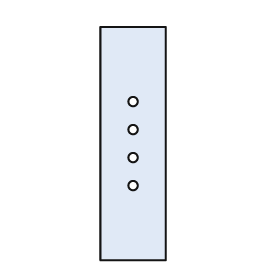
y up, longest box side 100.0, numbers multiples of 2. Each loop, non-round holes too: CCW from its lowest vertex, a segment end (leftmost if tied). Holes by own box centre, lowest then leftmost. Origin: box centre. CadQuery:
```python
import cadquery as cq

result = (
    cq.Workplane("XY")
    .moveTo(-14.0, -50.0)
    .lineTo(14.0, -50.0)
    .lineTo(14.0, 50.0)
    .lineTo(-14.0, 50.0)
    .close()
    .moveTo(0.0, -18.0)
    .circle(2.0)
    .moveTo(0.0, -6.0)
    .circle(2.0)
    .moveTo(0.0, 6.0)
    .circle(2.0)
    .moveTo(0.0, 18.0)
    .circle(2.0)
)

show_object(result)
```